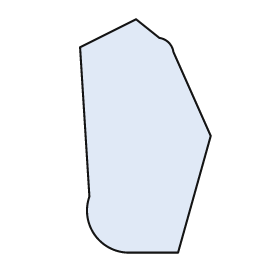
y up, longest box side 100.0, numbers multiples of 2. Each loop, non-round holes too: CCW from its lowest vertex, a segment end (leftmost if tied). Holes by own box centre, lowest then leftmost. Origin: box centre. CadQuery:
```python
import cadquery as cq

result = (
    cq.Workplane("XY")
    .moveTo(-8.0, -50.0)
    .lineTo(14.0, -50.0)
    .lineTo(28.0, 0.0)
    .lineTo(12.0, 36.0)
    .threePointArc((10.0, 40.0), (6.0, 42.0))
    .lineTo(-4.0, 50.0)
    .lineTo(-28.0, 38.0)
    .lineTo(-24.0, -26.0)
    .threePointArc((-22.0, -42.0), (-8.0, -50.0))
    .close()
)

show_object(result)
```